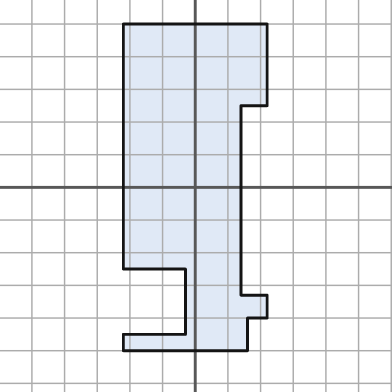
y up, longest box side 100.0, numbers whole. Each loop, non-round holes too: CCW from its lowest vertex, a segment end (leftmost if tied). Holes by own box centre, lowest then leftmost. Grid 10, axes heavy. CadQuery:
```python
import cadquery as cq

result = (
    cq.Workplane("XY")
    .moveTo(-22.0, -50.0)
    .lineTo(16.0, -50.0)
    .lineTo(16.0, -40.0)
    .lineTo(22.0, -40.0)
    .lineTo(22.0, -33.0)
    .lineTo(14.0, -33.0)
    .lineTo(14.0, 25.0)
    .lineTo(22.0, 25.0)
    .lineTo(22.0, 50.0)
    .lineTo(-22.0, 50.0)
    .lineTo(-22.0, -25.0)
    .lineTo(-3.0, -25.0)
    .lineTo(-3.0, -45.0)
    .lineTo(-22.0, -45.0)
    .close()
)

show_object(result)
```